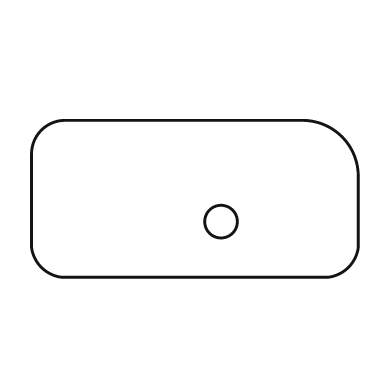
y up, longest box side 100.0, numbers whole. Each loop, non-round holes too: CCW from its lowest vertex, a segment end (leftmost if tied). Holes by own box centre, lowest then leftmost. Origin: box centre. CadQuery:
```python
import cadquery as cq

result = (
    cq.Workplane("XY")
    .moveTo(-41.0, -24.0)
    .lineTo(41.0, -24.0)
    .threePointArc((47.0, -21.0), (50.0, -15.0))
    .lineTo(50.0, 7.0)
    .threePointArc((45.0, 19.0), (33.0, 24.0))
    .lineTo(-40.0, 24.0)
    .threePointArc((-47.0, 21.0), (-50.0, 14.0))
    .lineTo(-50.0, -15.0)
    .threePointArc((-47.0, -21.0), (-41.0, -24.0))
    .close()
    .moveTo(8.0, -7.0)
    .circle(5.0)
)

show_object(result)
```